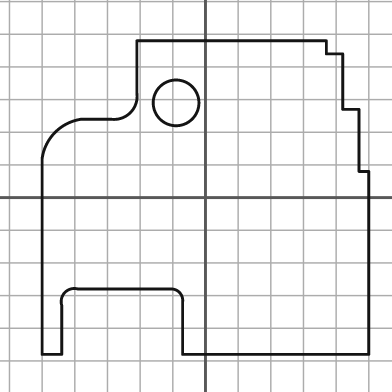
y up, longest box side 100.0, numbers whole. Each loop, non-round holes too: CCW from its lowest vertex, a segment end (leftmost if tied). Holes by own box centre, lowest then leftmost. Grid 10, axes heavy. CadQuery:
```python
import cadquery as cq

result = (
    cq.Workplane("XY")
    .moveTo(-50.0, -48.0)
    .lineTo(-44.0, -48.0)
    .lineTo(-44.0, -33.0)
    .threePointArc((-43.0, -29.0), (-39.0, -28.0))
    .lineTo(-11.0, -28.0)
    .threePointArc((-8.0, -29.0), (-7.0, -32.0))
    .lineTo(-7.0, -48.0)
    .lineTo(50.0, -48.0)
    .lineTo(50.0, 8.0)
    .lineTo(47.0, 8.0)
    .lineTo(47.0, 27.0)
    .lineTo(42.0, 27.0)
    .lineTo(42.0, 44.0)
    .lineTo(37.0, 44.0)
    .lineTo(37.0, 48.0)
    .lineTo(-21.0, 48.0)
    .lineTo(-21.0, 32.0)
    .threePointArc((-23.0, 26.0), (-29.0, 24.0))
    .lineTo(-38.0, 24.0)
    .threePointArc((-46.0, 20.0), (-50.0, 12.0))
    .close()
    .moveTo(-9.0, 29.0)
    .circle(7.0)
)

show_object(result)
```